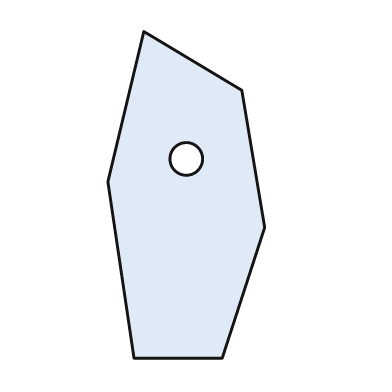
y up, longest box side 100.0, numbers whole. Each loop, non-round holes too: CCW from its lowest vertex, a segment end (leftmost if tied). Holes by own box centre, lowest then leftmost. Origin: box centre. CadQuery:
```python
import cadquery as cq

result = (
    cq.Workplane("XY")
    .moveTo(-16.0, -50.0)
    .lineTo(11.0, -50.0)
    .lineTo(24.0, -10.0)
    .lineTo(17.0, 32.0)
    .lineTo(-13.0, 50.0)
    .lineTo(-24.0, 4.0)
    .close()
    .moveTo(0.0, 11.0)
    .circle(5.0)
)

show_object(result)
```